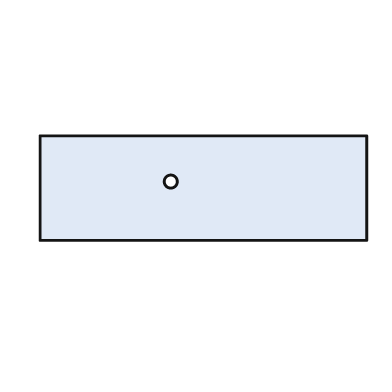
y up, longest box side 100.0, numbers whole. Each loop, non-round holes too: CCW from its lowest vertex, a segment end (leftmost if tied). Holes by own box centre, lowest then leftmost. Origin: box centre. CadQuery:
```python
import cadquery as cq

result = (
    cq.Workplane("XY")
    .moveTo(-50.0, -16.0)
    .lineTo(50.0, -16.0)
    .lineTo(50.0, 16.0)
    .lineTo(-50.0, 16.0)
    .close()
    .moveTo(-10.0, 2.0)
    .circle(2.0)
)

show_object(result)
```